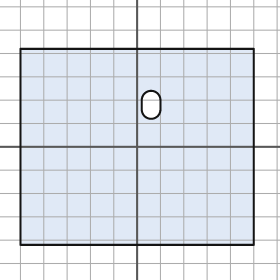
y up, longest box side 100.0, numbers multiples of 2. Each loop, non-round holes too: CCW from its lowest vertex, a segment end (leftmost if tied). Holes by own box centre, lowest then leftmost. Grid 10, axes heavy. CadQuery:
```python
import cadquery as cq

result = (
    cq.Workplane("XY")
    .moveTo(-50.0, -42.0)
    .lineTo(50.0, -42.0)
    .lineTo(50.0, 42.0)
    .lineTo(-50.0, 42.0)
    .close()
    .moveTo(2.0, 16.0)
    .threePointArc((6.0, 12.0), (10.0, 16.0))
    .lineTo(10.0, 20.0)
    .threePointArc((6.0, 24.0), (2.0, 20.0))
    .close()
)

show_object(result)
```